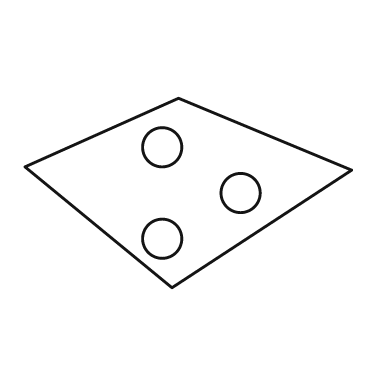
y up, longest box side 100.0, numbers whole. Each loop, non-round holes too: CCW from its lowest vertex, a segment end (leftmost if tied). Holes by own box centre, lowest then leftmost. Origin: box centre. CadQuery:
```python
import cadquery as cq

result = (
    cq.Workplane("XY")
    .moveTo(-5.0, -29.0)
    .lineTo(50.0, 7.0)
    .lineTo(-3.0, 29.0)
    .lineTo(-50.0, 8.0)
    .close()
    .moveTo(-8.0, -14.0)
    .circle(6.0)
    .moveTo(16.0, 0.0)
    .circle(6.0)
    .moveTo(-8.0, 14.0)
    .circle(6.0)
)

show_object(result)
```